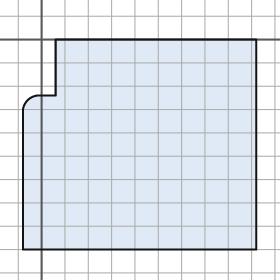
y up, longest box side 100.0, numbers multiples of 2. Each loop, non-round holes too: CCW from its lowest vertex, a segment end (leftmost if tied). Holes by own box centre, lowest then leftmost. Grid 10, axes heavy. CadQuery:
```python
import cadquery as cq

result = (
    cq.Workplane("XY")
    .moveTo(-8.0, -90.0)
    .lineTo(92.0, -90.0)
    .lineTo(92.0, 0.0)
    .lineTo(6.0, 0.0)
    .lineTo(6.0, -24.0)
    .lineTo(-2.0, -24.0)
    .threePointArc((-6.0, -26.0), (-8.0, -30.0))
    .close()
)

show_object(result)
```